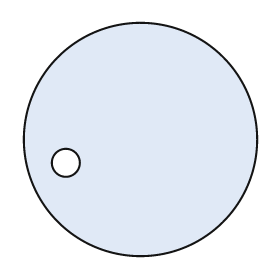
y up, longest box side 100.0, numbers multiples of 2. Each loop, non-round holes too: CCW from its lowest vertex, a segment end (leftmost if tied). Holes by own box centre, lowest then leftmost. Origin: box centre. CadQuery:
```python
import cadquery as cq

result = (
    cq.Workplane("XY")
    .moveTo(0.0, 0.0)
    .circle(50.0)
    .moveTo(-32.0, -10.0)
    .circle(6.0)
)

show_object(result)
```